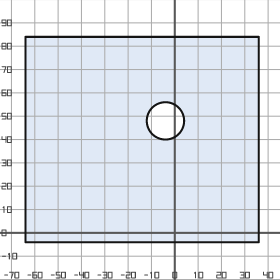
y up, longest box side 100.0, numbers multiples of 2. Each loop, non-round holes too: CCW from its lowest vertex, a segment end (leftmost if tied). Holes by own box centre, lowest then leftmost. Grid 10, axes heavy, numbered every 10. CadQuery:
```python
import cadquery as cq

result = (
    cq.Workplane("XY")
    .moveTo(-64.0, -4.0)
    .lineTo(36.0, -4.0)
    .lineTo(36.0, 84.0)
    .lineTo(-64.0, 84.0)
    .close()
    .moveTo(-4.0, 48.0)
    .circle(8.0)
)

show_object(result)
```